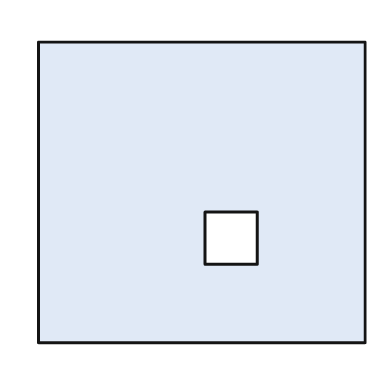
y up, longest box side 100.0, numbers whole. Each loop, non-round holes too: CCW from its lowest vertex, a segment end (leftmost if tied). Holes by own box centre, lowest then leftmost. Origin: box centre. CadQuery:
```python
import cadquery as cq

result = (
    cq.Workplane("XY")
    .moveTo(-50.0, -46.0)
    .lineTo(50.0, -46.0)
    .lineTo(50.0, 46.0)
    .lineTo(-50.0, 46.0)
    .close()
    .moveTo(1.0, -22.0)
    .lineTo(17.0, -22.0)
    .lineTo(17.0, -6.0)
    .lineTo(1.0, -6.0)
    .close()
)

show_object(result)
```